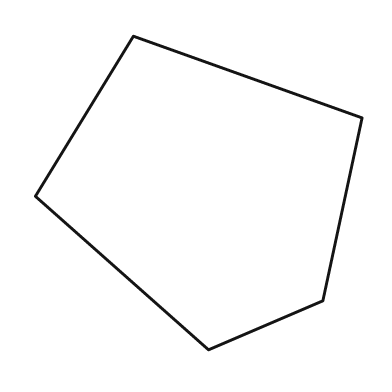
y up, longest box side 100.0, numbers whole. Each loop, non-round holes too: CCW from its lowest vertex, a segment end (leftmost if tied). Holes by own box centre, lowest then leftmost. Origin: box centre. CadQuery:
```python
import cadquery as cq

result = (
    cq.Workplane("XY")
    .moveTo(3.0, -48.0)
    .lineTo(38.0, -33.0)
    .lineTo(50.0, 23.0)
    .lineTo(-20.0, 48.0)
    .lineTo(-50.0, -1.0)
    .close()
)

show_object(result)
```